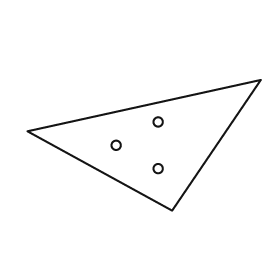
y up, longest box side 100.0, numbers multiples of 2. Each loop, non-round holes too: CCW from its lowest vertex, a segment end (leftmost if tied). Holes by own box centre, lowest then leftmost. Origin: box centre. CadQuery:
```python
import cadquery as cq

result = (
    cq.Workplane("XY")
    .moveTo(12.0, -28.0)
    .lineTo(50.0, 28.0)
    .lineTo(-50.0, 6.0)
    .close()
    .moveTo(6.0, -10.0)
    .circle(2.0)
    .moveTo(-12.0, 0.0)
    .circle(2.0)
    .moveTo(6.0, 10.0)
    .circle(2.0)
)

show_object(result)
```